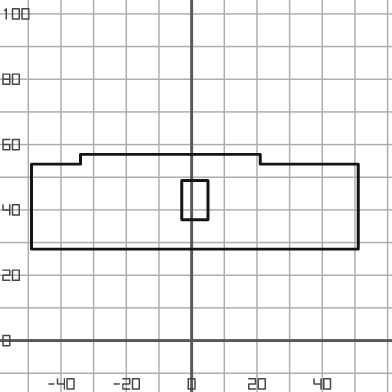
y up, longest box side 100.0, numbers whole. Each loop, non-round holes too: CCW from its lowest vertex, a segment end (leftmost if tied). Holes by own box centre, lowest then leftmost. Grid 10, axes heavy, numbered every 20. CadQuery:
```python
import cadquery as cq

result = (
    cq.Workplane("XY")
    .moveTo(-49.0, 28.0)
    .lineTo(51.0, 28.0)
    .lineTo(51.0, 54.0)
    .lineTo(21.0, 54.0)
    .lineTo(21.0, 57.0)
    .lineTo(-34.0, 57.0)
    .lineTo(-34.0, 54.0)
    .lineTo(-49.0, 54.0)
    .close()
    .moveTo(-3.0, 37.0)
    .lineTo(5.0, 37.0)
    .lineTo(5.0, 49.0)
    .lineTo(-3.0, 49.0)
    .close()
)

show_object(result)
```